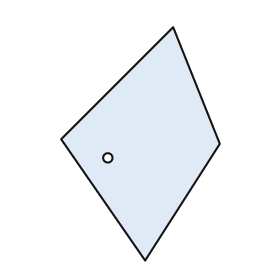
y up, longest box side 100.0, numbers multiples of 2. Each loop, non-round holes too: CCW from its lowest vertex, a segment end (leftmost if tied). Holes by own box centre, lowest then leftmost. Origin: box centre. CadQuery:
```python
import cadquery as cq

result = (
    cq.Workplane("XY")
    .moveTo(2.0, -50.0)
    .lineTo(34.0, 0.0)
    .lineTo(14.0, 50.0)
    .lineTo(-34.0, 2.0)
    .close()
    .moveTo(-14.0, -6.0)
    .circle(2.0)
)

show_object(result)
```